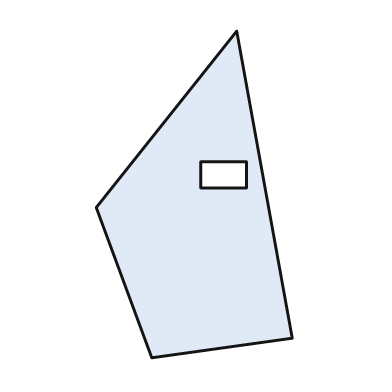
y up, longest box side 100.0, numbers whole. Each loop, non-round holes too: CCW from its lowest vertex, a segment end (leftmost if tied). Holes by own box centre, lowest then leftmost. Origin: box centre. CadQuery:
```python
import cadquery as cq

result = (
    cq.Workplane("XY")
    .moveTo(-13.0, -50.0)
    .lineTo(30.0, -44.0)
    .lineTo(13.0, 50.0)
    .lineTo(-30.0, -4.0)
    .close()
    .moveTo(2.0, 2.0)
    .lineTo(16.0, 2.0)
    .lineTo(16.0, 10.0)
    .lineTo(2.0, 10.0)
    .close()
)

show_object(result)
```